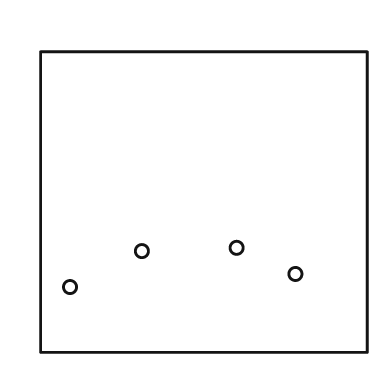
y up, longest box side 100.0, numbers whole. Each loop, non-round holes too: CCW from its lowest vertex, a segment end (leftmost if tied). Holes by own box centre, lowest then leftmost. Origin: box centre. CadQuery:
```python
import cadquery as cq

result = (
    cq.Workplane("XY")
    .moveTo(-50.0, -46.0)
    .lineTo(50.0, -46.0)
    .lineTo(50.0, 46.0)
    .lineTo(-50.0, 46.0)
    .close()
    .moveTo(-41.0, -26.0)
    .circle(2.0)
    .moveTo(28.0, -22.0)
    .circle(2.0)
    .moveTo(-19.0, -15.0)
    .circle(2.0)
    .moveTo(10.0, -14.0)
    .circle(2.0)
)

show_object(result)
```